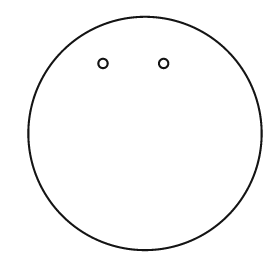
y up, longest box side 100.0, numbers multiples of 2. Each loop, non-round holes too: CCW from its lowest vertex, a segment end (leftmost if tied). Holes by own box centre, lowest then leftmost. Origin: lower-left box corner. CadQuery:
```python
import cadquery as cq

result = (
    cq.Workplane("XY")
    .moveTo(50.0, 50.0)
    .circle(50.0)
    .moveTo(32.0, 80.0)
    .circle(2.0)
    .moveTo(58.0, 80.0)
    .circle(2.0)
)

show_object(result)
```